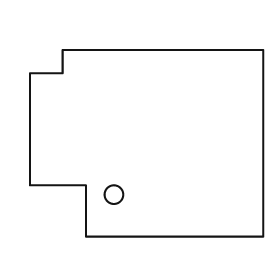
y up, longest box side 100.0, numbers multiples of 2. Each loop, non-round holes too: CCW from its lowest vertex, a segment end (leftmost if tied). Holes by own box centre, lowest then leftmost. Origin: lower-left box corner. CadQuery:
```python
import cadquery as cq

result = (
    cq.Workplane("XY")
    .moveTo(24.0, 0.0)
    .lineTo(100.0, 0.0)
    .lineTo(100.0, 80.0)
    .lineTo(14.0, 80.0)
    .lineTo(14.0, 70.0)
    .lineTo(0.0, 70.0)
    .lineTo(0.0, 22.0)
    .lineTo(24.0, 22.0)
    .close()
    .moveTo(36.0, 18.0)
    .circle(4.0)
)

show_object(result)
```